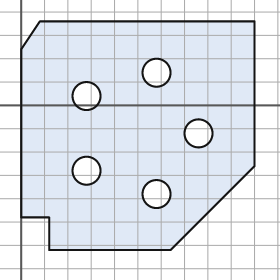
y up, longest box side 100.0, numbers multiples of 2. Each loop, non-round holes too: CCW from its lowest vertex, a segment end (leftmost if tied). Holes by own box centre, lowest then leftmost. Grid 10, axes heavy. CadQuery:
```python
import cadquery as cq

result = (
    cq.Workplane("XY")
    .moveTo(12.0, -62.0)
    .lineTo(64.0, -62.0)
    .lineTo(100.0, -26.0)
    .lineTo(100.0, 36.0)
    .lineTo(8.0, 36.0)
    .lineTo(0.0, 24.0)
    .lineTo(0.0, -48.0)
    .lineTo(12.0, -48.0)
    .close()
    .moveTo(58.0, -38.0)
    .circle(6.0)
    .moveTo(28.0, -28.0)
    .circle(6.0)
    .moveTo(76.0, -12.0)
    .circle(6.0)
    .moveTo(28.0, 4.0)
    .circle(6.0)
    .moveTo(58.0, 14.0)
    .circle(6.0)
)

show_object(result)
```